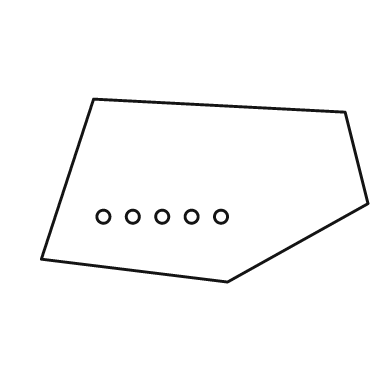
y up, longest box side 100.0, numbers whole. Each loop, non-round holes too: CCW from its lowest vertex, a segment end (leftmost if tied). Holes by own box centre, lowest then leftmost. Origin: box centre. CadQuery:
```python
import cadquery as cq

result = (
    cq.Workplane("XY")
    .moveTo(7.0, -28.0)
    .lineTo(50.0, -4.0)
    .lineTo(43.0, 24.0)
    .lineTo(-34.0, 28.0)
    .lineTo(-50.0, -21.0)
    .close()
    .moveTo(-31.0, -8.0)
    .circle(2.0)
    .moveTo(-22.0, -8.0)
    .circle(2.0)
    .moveTo(-13.0, -8.0)
    .circle(2.0)
    .moveTo(-4.0, -8.0)
    .circle(2.0)
    .moveTo(5.0, -8.0)
    .circle(2.0)
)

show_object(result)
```